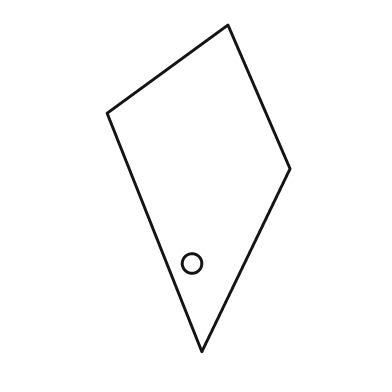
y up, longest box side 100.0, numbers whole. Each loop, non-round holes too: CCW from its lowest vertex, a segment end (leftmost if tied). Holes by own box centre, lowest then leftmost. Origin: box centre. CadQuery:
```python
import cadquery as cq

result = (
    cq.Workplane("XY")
    .moveTo(1.0, -50.0)
    .lineTo(28.0, 6.0)
    .lineTo(9.0, 50.0)
    .lineTo(-28.0, 23.0)
    .close()
    .moveTo(-2.0, -23.0)
    .circle(3.0)
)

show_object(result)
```